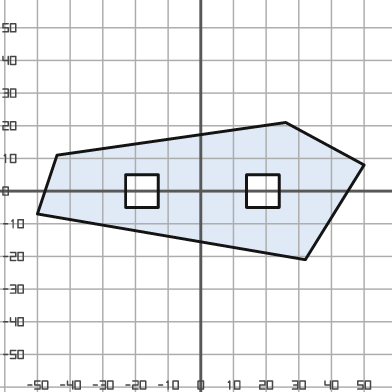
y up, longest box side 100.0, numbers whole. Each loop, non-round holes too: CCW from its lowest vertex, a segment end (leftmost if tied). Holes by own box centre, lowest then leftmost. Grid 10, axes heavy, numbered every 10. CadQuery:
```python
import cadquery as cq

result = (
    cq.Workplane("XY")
    .moveTo(32.0, -21.0)
    .lineTo(50.0, 8.0)
    .lineTo(26.0, 21.0)
    .lineTo(-44.0, 11.0)
    .lineTo(-50.0, -7.0)
    .close()
    .moveTo(-23.0, -5.0)
    .lineTo(-13.0, -5.0)
    .lineTo(-13.0, 5.0)
    .lineTo(-23.0, 5.0)
    .close()
    .moveTo(14.0, -5.0)
    .lineTo(24.0, -5.0)
    .lineTo(24.0, 5.0)
    .lineTo(14.0, 5.0)
    .close()
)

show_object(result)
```